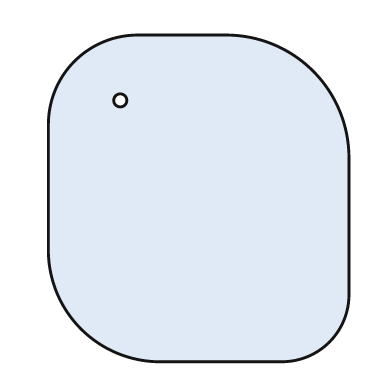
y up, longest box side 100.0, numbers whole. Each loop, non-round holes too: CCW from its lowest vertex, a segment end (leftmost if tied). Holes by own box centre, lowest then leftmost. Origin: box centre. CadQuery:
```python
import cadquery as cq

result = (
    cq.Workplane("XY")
    .moveTo(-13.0, -50.0)
    .lineTo(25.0, -50.0)
    .threePointArc((40.0, -44.0), (46.0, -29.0))
    .lineTo(46.0, 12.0)
    .threePointArc((35.0, 39.0), (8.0, 50.0))
    .lineTo(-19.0, 50.0)
    .threePointArc((-38.0, 42.0), (-46.0, 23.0))
    .lineTo(-46.0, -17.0)
    .threePointArc((-36.0, -40.0), (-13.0, -50.0))
    .close()
    .moveTo(-24.0, 30.0)
    .circle(2.0)
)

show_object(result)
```